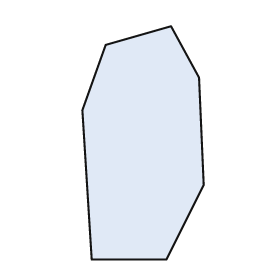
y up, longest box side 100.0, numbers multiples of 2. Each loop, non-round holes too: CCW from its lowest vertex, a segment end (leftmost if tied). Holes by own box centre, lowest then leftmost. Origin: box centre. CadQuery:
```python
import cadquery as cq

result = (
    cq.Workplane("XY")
    .moveTo(-22.0, -50.0)
    .lineTo(10.0, -50.0)
    .lineTo(26.0, -18.0)
    .lineTo(24.0, 28.0)
    .lineTo(12.0, 50.0)
    .lineTo(-16.0, 42.0)
    .lineTo(-26.0, 14.0)
    .close()
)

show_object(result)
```